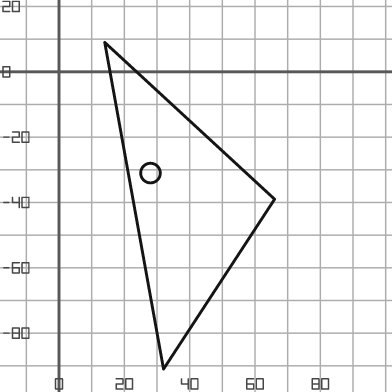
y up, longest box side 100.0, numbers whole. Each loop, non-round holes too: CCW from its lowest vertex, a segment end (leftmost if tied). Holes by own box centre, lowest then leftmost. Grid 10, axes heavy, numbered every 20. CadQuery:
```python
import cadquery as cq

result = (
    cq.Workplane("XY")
    .moveTo(32.0, -91.0)
    .lineTo(66.0, -39.0)
    .lineTo(14.0, 9.0)
    .close()
    .moveTo(28.0, -31.0)
    .circle(3.0)
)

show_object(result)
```